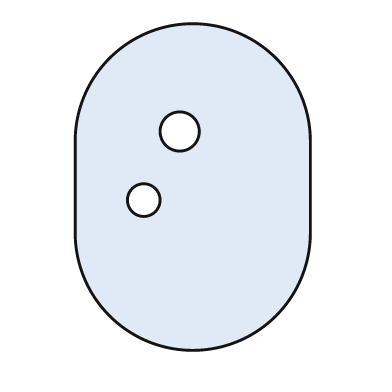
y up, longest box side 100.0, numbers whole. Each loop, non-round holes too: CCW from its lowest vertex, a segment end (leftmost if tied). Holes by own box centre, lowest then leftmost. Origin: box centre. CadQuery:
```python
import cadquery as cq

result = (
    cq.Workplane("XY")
    .moveTo(-36.0, -14.0)
    .threePointArc((0.0, -50.0), (36.0, -14.0))
    .lineTo(36.0, 14.0)
    .threePointArc((0.0, 50.0), (-36.0, 14.0))
    .close()
    .moveTo(-15.0, -4.0)
    .circle(5.0)
    .moveTo(-4.0, 17.0)
    .circle(6.0)
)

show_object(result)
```